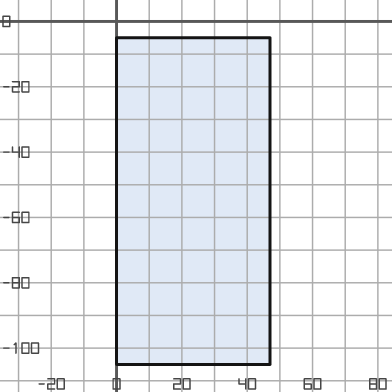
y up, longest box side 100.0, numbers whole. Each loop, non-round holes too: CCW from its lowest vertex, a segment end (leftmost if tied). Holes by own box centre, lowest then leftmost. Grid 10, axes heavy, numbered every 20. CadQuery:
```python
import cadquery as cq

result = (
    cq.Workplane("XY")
    .moveTo(0.0, -105.0)
    .lineTo(47.0, -105.0)
    .lineTo(47.0, -5.0)
    .lineTo(0.0, -5.0)
    .close()
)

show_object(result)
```